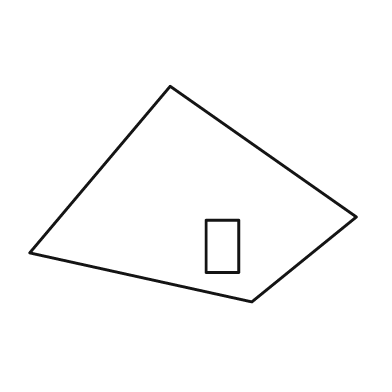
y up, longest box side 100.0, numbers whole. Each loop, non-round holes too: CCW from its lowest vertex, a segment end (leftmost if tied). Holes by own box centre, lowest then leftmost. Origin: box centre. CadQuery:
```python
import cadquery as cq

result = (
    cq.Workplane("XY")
    .moveTo(18.0, -33.0)
    .lineTo(50.0, -7.0)
    .lineTo(-7.0, 33.0)
    .lineTo(-50.0, -18.0)
    .close()
    .moveTo(4.0, -24.0)
    .lineTo(14.0, -24.0)
    .lineTo(14.0, -8.0)
    .lineTo(4.0, -8.0)
    .close()
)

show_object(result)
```